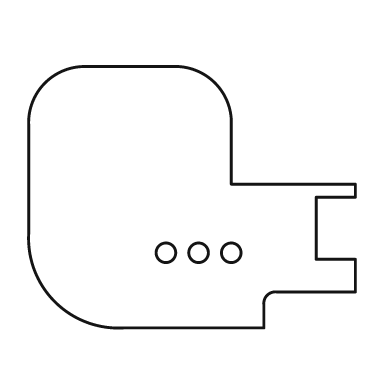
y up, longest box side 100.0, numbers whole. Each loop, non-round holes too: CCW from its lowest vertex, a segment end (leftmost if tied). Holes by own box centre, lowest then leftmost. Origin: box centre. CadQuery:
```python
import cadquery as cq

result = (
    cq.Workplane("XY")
    .moveTo(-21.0, -40.0)
    .lineTo(22.0, -40.0)
    .lineTo(22.0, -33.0)
    .threePointArc((23.0, -30.0), (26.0, -29.0))
    .lineTo(50.0, -29.0)
    .lineTo(50.0, -19.0)
    .lineTo(38.0, -19.0)
    .lineTo(38.0, 0.0)
    .lineTo(50.0, 0.0)
    .lineTo(50.0, 4.0)
    .lineTo(12.0, 4.0)
    .lineTo(12.0, 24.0)
    .threePointArc((7.0, 35.0), (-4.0, 40.0))
    .lineTo(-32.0, 40.0)
    .threePointArc((-45.0, 35.0), (-50.0, 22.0))
    .lineTo(-50.0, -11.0)
    .threePointArc((-42.0, -32.0), (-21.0, -40.0))
    .close()
    .moveTo(-8.0, -17.0)
    .circle(3.0)
    .moveTo(2.0, -17.0)
    .circle(3.0)
    .moveTo(12.0, -17.0)
    .circle(3.0)
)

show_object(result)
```